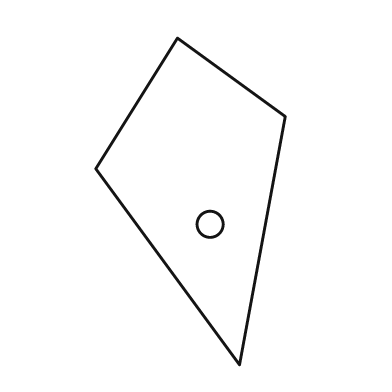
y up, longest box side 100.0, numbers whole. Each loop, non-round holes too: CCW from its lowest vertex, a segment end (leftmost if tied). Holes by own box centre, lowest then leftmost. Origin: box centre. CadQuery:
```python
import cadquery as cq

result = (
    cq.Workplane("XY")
    .moveTo(15.0, -50.0)
    .lineTo(29.0, 26.0)
    .lineTo(-4.0, 50.0)
    .lineTo(-29.0, 10.0)
    .close()
    .moveTo(6.0, -7.0)
    .circle(4.0)
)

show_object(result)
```